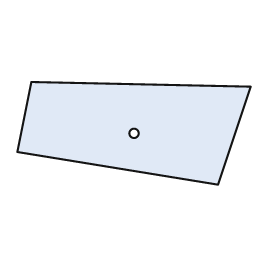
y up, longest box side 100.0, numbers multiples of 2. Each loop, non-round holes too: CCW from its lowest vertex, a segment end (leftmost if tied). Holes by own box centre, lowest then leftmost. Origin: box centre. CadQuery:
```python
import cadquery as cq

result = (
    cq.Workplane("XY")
    .moveTo(36.0, -22.0)
    .lineTo(50.0, 20.0)
    .lineTo(-44.0, 22.0)
    .lineTo(-50.0, -8.0)
    .close()
    .moveTo(0.0, 0.0)
    .circle(2.0)
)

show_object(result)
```